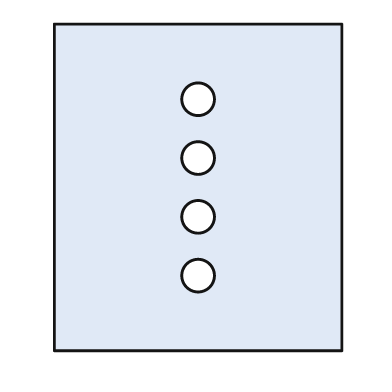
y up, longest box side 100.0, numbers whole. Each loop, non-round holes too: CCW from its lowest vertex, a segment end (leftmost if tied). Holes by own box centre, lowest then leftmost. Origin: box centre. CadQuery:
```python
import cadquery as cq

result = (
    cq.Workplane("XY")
    .moveTo(-44.0, -50.0)
    .lineTo(44.0, -50.0)
    .lineTo(44.0, 50.0)
    .lineTo(-44.0, 50.0)
    .close()
    .moveTo(0.0, -27.0)
    .circle(5.0)
    .moveTo(0.0, -9.0)
    .circle(5.0)
    .moveTo(0.0, 9.0)
    .circle(5.0)
    .moveTo(0.0, 27.0)
    .circle(5.0)
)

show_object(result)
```